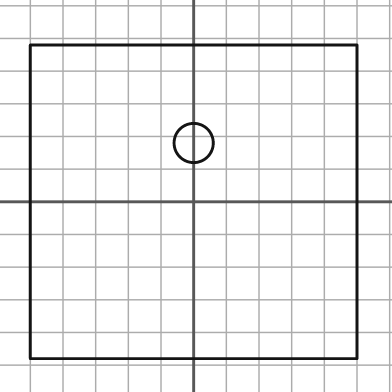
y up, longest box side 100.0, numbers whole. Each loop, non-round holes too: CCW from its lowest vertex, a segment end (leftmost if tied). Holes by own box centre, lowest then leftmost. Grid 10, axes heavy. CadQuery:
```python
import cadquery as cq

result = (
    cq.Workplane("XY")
    .moveTo(-50.0, -48.0)
    .lineTo(50.0, -48.0)
    .lineTo(50.0, 48.0)
    .lineTo(-50.0, 48.0)
    .close()
    .moveTo(0.0, 18.0)
    .circle(6.0)
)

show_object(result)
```